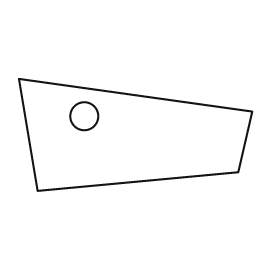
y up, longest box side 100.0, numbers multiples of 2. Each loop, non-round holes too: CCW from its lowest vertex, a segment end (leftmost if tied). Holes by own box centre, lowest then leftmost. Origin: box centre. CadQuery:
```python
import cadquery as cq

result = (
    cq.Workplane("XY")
    .moveTo(-42.0, -24.0)
    .lineTo(44.0, -16.0)
    .lineTo(50.0, 10.0)
    .lineTo(-50.0, 24.0)
    .close()
    .moveTo(-22.0, 8.0)
    .circle(6.0)
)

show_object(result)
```